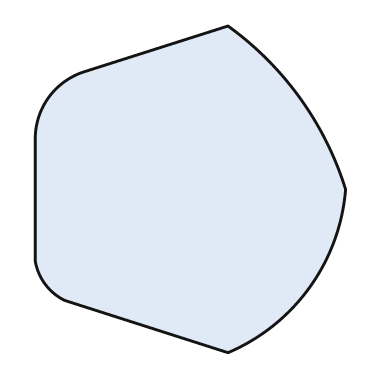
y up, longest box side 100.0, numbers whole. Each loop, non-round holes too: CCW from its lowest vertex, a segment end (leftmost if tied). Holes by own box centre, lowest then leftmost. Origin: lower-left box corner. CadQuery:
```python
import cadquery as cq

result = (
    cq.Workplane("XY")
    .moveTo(59.0, 0.0)
    .threePointArc((84.0, 20.0), (95.0, 50.0))
    .threePointArc((81.0, 78.0), (59.0, 100.0))
    .lineTo(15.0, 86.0)
    .threePointArc((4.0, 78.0), (0.0, 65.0))
    .lineTo(0.0, 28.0)
    .threePointArc((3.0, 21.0), (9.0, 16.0))
    .close()
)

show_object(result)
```